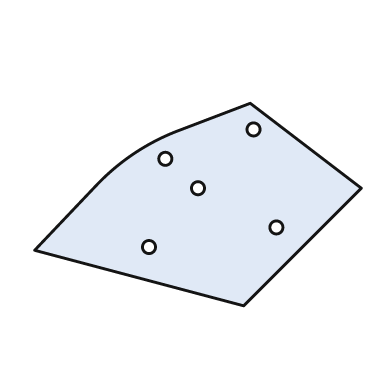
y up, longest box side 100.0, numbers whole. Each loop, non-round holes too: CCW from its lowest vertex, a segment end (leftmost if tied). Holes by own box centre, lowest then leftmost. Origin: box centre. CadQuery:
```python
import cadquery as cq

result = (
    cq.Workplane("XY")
    .moveTo(14.0, -31.0)
    .lineTo(50.0, 5.0)
    .lineTo(16.0, 31.0)
    .lineTo(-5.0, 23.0)
    .threePointArc((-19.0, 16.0), (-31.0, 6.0))
    .lineTo(-50.0, -14.0)
    .close()
    .moveTo(-15.0, -13.0)
    .circle(2.0)
    .moveTo(24.0, -7.0)
    .circle(2.0)
    .moveTo(0.0, 5.0)
    .circle(2.0)
    .moveTo(-10.0, 14.0)
    .circle(2.0)
    .moveTo(17.0, 23.0)
    .circle(2.0)
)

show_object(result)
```